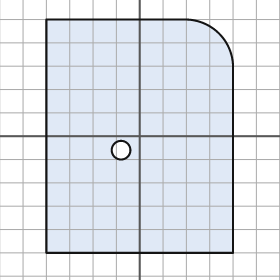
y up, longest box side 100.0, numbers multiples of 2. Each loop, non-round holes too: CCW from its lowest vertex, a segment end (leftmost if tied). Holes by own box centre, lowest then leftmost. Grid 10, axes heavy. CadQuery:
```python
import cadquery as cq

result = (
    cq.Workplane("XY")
    .moveTo(-40.0, -50.0)
    .lineTo(40.0, -50.0)
    .lineTo(40.0, 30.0)
    .threePointArc((34.0, 44.0), (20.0, 50.0))
    .lineTo(-40.0, 50.0)
    .close()
    .moveTo(-8.0, -6.0)
    .circle(4.0)
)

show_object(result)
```